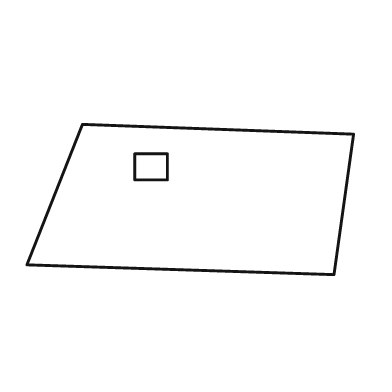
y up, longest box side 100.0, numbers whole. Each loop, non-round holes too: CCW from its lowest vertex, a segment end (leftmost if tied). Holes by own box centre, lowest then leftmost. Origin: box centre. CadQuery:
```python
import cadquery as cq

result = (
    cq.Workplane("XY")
    .moveTo(44.0, -23.0)
    .lineTo(50.0, 20.0)
    .lineTo(-33.0, 23.0)
    .lineTo(-50.0, -20.0)
    .close()
    .moveTo(-17.0, 6.0)
    .lineTo(-7.0, 6.0)
    .lineTo(-7.0, 14.0)
    .lineTo(-17.0, 14.0)
    .close()
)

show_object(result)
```